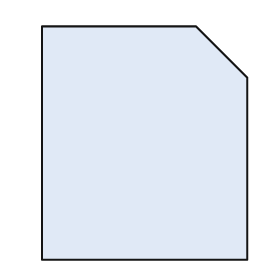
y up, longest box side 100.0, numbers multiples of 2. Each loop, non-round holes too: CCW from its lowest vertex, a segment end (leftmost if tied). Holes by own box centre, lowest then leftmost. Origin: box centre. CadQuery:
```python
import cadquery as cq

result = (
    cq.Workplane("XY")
    .moveTo(-44.0, -50.0)
    .lineTo(44.0, -50.0)
    .lineTo(44.0, 28.0)
    .lineTo(22.0, 50.0)
    .lineTo(-44.0, 50.0)
    .close()
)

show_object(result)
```